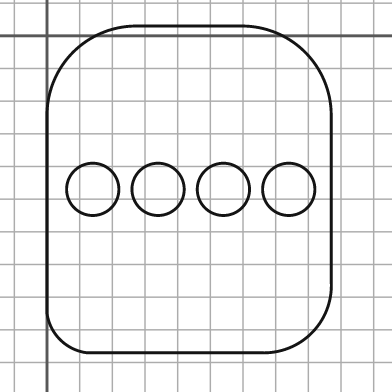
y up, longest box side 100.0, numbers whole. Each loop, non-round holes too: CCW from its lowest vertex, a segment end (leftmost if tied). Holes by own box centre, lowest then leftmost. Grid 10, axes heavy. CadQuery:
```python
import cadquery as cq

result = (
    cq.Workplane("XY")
    .moveTo(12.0, -97.0)
    .lineTo(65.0, -97.0)
    .threePointArc((81.0, -91.0), (87.0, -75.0))
    .lineTo(87.0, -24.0)
    .threePointArc((79.0, -5.0), (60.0, 3.0))
    .lineTo(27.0, 3.0)
    .threePointArc((8.0, -5.0), (0.0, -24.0))
    .lineTo(0.0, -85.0)
    .threePointArc((4.0, -93.0), (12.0, -97.0))
    .close()
    .moveTo(14.0, -47.0)
    .circle(8.0)
    .moveTo(34.0, -47.0)
    .circle(8.0)
    .moveTo(54.0, -47.0)
    .circle(8.0)
    .moveTo(74.0, -47.0)
    .circle(8.0)
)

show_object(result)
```